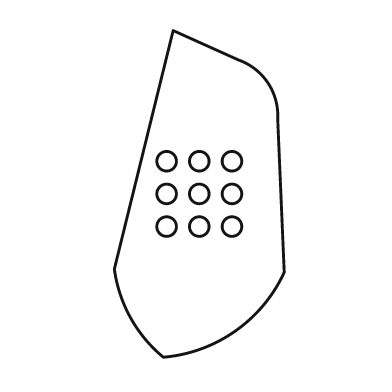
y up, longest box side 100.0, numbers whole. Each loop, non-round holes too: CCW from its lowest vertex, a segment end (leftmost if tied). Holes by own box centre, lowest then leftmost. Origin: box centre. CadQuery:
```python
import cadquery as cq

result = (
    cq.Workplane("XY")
    .moveTo(-11.0, -50.0)
    .threePointArc((11.0, -42.0), (26.0, -24.0))
    .lineTo(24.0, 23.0)
    .threePointArc((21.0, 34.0), (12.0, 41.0))
    .lineTo(-8.0, 50.0)
    .lineTo(-26.0, -23.0)
    .threePointArc((-21.0, -38.0), (-11.0, -50.0))
    .close()
    .moveTo(-10.0, -10.0)
    .circle(3.0)
    .moveTo(0.0, -10.0)
    .circle(3.0)
    .moveTo(10.0, -10.0)
    .circle(3.0)
    .moveTo(-10.0, 0.0)
    .circle(3.0)
    .moveTo(0.0, 0.0)
    .circle(3.0)
    .moveTo(10.0, 0.0)
    .circle(3.0)
    .moveTo(-10.0, 10.0)
    .circle(3.0)
    .moveTo(0.0, 10.0)
    .circle(3.0)
    .moveTo(10.0, 10.0)
    .circle(3.0)
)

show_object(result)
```